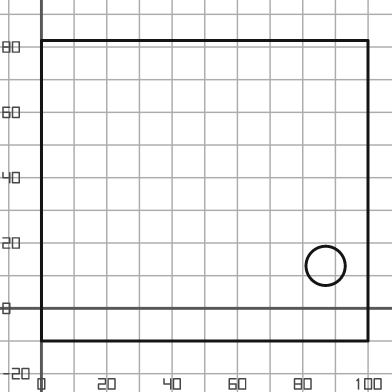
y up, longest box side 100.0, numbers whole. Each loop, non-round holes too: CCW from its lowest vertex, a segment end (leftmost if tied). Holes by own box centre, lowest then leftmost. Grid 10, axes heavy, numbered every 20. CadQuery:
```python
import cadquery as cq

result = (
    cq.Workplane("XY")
    .moveTo(0.0, -10.0)
    .lineTo(100.0, -10.0)
    .lineTo(100.0, 82.0)
    .lineTo(0.0, 82.0)
    .close()
    .moveTo(87.0, 13.0)
    .circle(6.0)
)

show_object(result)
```